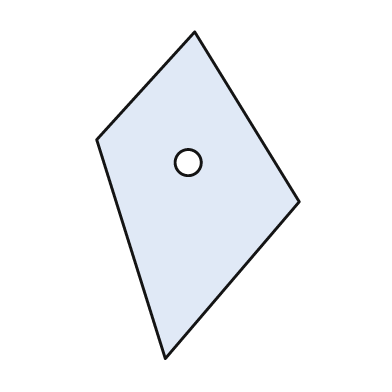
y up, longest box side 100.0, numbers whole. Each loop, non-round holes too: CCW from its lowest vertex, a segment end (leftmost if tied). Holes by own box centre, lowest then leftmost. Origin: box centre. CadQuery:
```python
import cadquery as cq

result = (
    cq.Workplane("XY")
    .moveTo(-10.0, -50.0)
    .lineTo(31.0, -2.0)
    .lineTo(-1.0, 50.0)
    .lineTo(-31.0, 17.0)
    .close()
    .moveTo(-3.0, 10.0)
    .circle(4.0)
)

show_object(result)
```